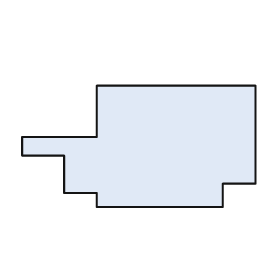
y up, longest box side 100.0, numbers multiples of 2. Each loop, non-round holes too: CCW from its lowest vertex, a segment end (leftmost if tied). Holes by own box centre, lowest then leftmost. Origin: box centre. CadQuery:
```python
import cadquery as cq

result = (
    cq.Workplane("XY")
    .moveTo(-18.0, -26.0)
    .lineTo(36.0, -26.0)
    .lineTo(36.0, -16.0)
    .lineTo(50.0, -16.0)
    .lineTo(50.0, 26.0)
    .lineTo(-18.0, 26.0)
    .lineTo(-18.0, 4.0)
    .lineTo(-50.0, 4.0)
    .lineTo(-50.0, -4.0)
    .lineTo(-32.0, -4.0)
    .lineTo(-32.0, -20.0)
    .lineTo(-18.0, -20.0)
    .close()
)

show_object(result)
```